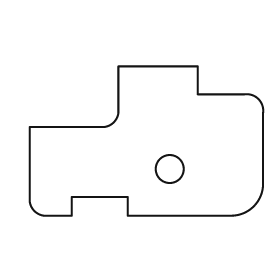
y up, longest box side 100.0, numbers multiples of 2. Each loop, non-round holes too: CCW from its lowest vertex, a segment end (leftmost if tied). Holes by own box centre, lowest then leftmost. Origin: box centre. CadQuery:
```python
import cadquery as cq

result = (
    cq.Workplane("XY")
    .moveTo(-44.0, -32.0)
    .lineTo(-32.0, -32.0)
    .lineTo(-32.0, -24.0)
    .lineTo(-8.0, -24.0)
    .lineTo(-8.0, -32.0)
    .lineTo(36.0, -32.0)
    .threePointArc((46.0, -28.0), (50.0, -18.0))
    .lineTo(50.0, 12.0)
    .threePointArc((48.0, 18.0), (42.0, 20.0))
    .lineTo(22.0, 20.0)
    .lineTo(22.0, 32.0)
    .lineTo(-12.0, 32.0)
    .lineTo(-12.0, 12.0)
    .threePointArc((-14.0, 8.0), (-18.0, 6.0))
    .lineTo(-50.0, 6.0)
    .lineTo(-50.0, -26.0)
    .threePointArc((-48.0, -30.0), (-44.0, -32.0))
    .close()
    .moveTo(10.0, -12.0)
    .circle(6.0)
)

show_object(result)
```